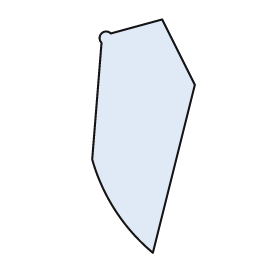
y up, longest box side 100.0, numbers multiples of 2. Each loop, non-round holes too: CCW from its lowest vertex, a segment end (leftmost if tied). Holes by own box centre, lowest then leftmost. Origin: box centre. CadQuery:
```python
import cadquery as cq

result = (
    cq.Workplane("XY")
    .moveTo(4.0, -50.0)
    .lineTo(22.0, 22.0)
    .lineTo(8.0, 50.0)
    .lineTo(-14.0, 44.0)
    .threePointArc((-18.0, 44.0), (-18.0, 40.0))
    .lineTo(-22.0, -10.0)
    .threePointArc((-12.0, -32.0), (4.0, -50.0))
    .close()
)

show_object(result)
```